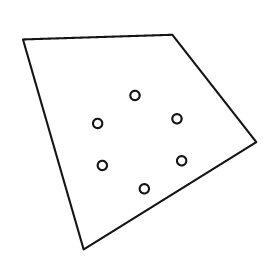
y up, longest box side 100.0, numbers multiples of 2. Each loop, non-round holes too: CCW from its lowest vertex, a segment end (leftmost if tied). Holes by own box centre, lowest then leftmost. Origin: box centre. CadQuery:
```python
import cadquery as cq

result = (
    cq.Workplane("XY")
    .moveTo(-24.0, -46.0)
    .lineTo(50.0, 0.0)
    .lineTo(14.0, 46.0)
    .lineTo(-50.0, 44.0)
    .close()
    .moveTo(2.0, -20.0)
    .circle(2.0)
    .moveTo(-16.0, -10.0)
    .circle(2.0)
    .moveTo(18.0, -8.0)
    .circle(2.0)
    .moveTo(-18.0, 8.0)
    .circle(2.0)
    .moveTo(16.0, 10.0)
    .circle(2.0)
    .moveTo(-2.0, 20.0)
    .circle(2.0)
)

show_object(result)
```